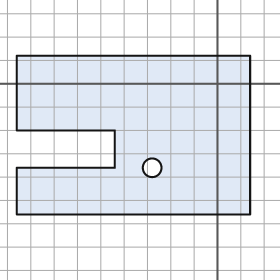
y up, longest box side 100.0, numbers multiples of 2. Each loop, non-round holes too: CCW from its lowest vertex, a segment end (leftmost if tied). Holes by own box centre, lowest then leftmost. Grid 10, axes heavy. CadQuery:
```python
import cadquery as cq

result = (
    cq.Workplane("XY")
    .moveTo(-86.0, -56.0)
    .lineTo(14.0, -56.0)
    .lineTo(14.0, 12.0)
    .lineTo(-86.0, 12.0)
    .lineTo(-86.0, -20.0)
    .lineTo(-44.0, -20.0)
    .lineTo(-44.0, -36.0)
    .lineTo(-86.0, -36.0)
    .close()
    .moveTo(-28.0, -36.0)
    .circle(4.0)
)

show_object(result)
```